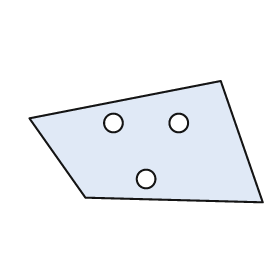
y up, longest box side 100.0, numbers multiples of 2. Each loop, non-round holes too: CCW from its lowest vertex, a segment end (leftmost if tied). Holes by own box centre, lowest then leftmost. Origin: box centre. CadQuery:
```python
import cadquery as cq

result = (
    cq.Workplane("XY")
    .moveTo(50.0, -26.0)
    .lineTo(32.0, 26.0)
    .lineTo(-50.0, 10.0)
    .lineTo(-26.0, -24.0)
    .close()
    .moveTo(0.0, -16.0)
    .circle(4.0)
    .moveTo(-14.0, 8.0)
    .circle(4.0)
    .moveTo(14.0, 8.0)
    .circle(4.0)
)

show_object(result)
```